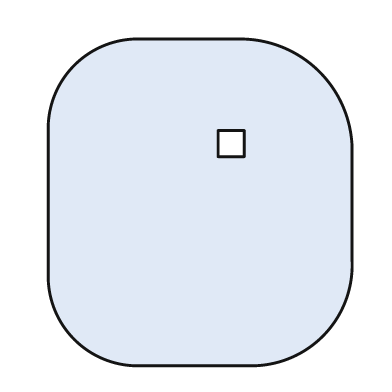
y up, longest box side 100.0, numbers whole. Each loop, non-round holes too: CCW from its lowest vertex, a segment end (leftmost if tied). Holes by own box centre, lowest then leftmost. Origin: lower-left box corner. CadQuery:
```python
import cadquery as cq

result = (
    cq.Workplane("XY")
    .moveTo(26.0, 0.0)
    .lineTo(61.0, 0.0)
    .threePointArc((84.0, 9.0), (93.0, 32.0))
    .lineTo(93.0, 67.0)
    .threePointArc((83.0, 90.0), (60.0, 100.0))
    .lineTo(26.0, 100.0)
    .threePointArc((8.0, 92.0), (0.0, 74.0))
    .lineTo(0.0, 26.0)
    .threePointArc((8.0, 8.0), (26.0, 0.0))
    .close()
    .moveTo(52.0, 64.0)
    .lineTo(60.0, 64.0)
    .lineTo(60.0, 72.0)
    .lineTo(52.0, 72.0)
    .close()
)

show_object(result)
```